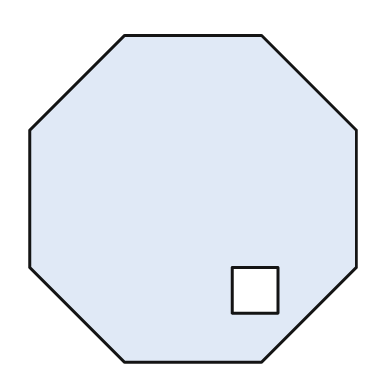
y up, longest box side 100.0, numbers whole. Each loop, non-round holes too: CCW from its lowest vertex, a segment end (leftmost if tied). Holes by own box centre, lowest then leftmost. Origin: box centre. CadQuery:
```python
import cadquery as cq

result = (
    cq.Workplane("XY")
    .moveTo(-21.0, -50.0)
    .lineTo(21.0, -50.0)
    .lineTo(50.0, -21.0)
    .lineTo(50.0, 21.0)
    .lineTo(21.0, 50.0)
    .lineTo(-21.0, 50.0)
    .lineTo(-50.0, 21.0)
    .lineTo(-50.0, -21.0)
    .close()
    .moveTo(12.0, -35.0)
    .lineTo(26.0, -35.0)
    .lineTo(26.0, -21.0)
    .lineTo(12.0, -21.0)
    .close()
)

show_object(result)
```